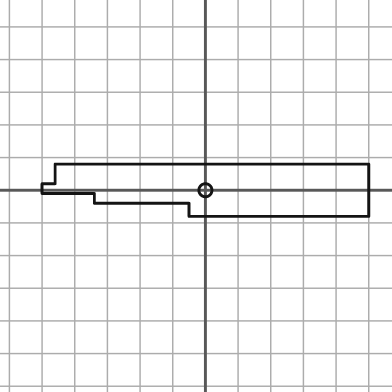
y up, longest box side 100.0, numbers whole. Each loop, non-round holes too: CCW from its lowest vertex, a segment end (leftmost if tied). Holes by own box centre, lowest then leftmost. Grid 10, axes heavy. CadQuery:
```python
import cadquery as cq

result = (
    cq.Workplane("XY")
    .moveTo(-5.0, -8.0)
    .lineTo(50.0, -8.0)
    .lineTo(50.0, 8.0)
    .lineTo(-46.0, 8.0)
    .lineTo(-46.0, 2.0)
    .lineTo(-50.0, 2.0)
    .lineTo(-50.0, -1.0)
    .lineTo(-34.0, -1.0)
    .lineTo(-34.0, -4.0)
    .lineTo(-5.0, -4.0)
    .close()
    .moveTo(0.0, 0.0)
    .circle(2.0)
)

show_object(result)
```